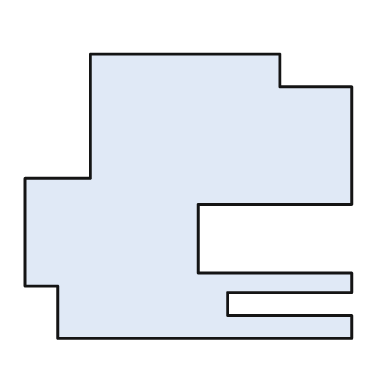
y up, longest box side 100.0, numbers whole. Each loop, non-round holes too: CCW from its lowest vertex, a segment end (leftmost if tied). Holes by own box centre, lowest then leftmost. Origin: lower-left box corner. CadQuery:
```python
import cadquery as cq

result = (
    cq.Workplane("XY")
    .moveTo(10.0, 0.0)
    .lineTo(100.0, 0.0)
    .lineTo(100.0, 7.0)
    .lineTo(62.0, 7.0)
    .lineTo(62.0, 14.0)
    .lineTo(100.0, 14.0)
    .lineTo(100.0, 20.0)
    .lineTo(53.0, 20.0)
    .lineTo(53.0, 41.0)
    .lineTo(100.0, 41.0)
    .lineTo(100.0, 77.0)
    .lineTo(78.0, 77.0)
    .lineTo(78.0, 87.0)
    .lineTo(20.0, 87.0)
    .lineTo(20.0, 49.0)
    .lineTo(0.0, 49.0)
    .lineTo(0.0, 16.0)
    .lineTo(10.0, 16.0)
    .close()
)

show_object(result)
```